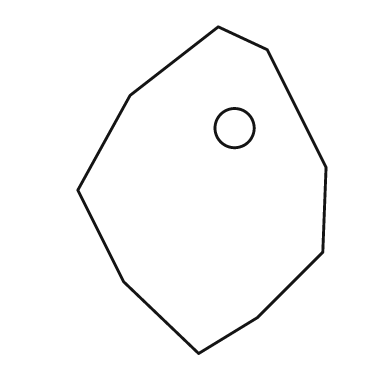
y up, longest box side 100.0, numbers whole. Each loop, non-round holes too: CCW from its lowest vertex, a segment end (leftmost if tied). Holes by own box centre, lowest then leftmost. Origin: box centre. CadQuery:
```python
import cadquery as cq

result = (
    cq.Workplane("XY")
    .moveTo(-1.0, -50.0)
    .lineTo(17.0, -39.0)
    .lineTo(37.0, -19.0)
    .lineTo(38.0, 7.0)
    .lineTo(20.0, 43.0)
    .lineTo(5.0, 50.0)
    .lineTo(-22.0, 29.0)
    .lineTo(-38.0, 0.0)
    .lineTo(-24.0, -28.0)
    .close()
    .moveTo(10.0, 19.0)
    .circle(6.0)
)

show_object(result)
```